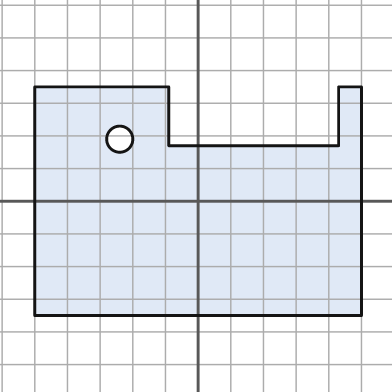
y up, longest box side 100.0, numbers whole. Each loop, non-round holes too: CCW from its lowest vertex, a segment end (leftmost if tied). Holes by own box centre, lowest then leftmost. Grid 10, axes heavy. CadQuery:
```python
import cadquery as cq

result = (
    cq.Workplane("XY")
    .moveTo(-50.0, -35.0)
    .lineTo(50.0, -35.0)
    .lineTo(50.0, 35.0)
    .lineTo(43.0, 35.0)
    .lineTo(43.0, 17.0)
    .lineTo(-9.0, 17.0)
    .lineTo(-9.0, 35.0)
    .lineTo(-50.0, 35.0)
    .close()
    .moveTo(-24.0, 19.0)
    .circle(4.0)
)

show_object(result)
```